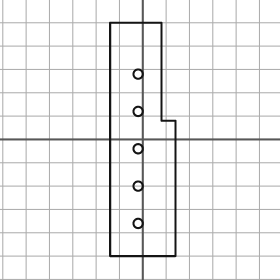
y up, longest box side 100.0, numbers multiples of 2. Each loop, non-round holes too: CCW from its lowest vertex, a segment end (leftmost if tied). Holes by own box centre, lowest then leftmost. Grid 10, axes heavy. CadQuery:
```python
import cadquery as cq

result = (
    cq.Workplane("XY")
    .moveTo(-14.0, -50.0)
    .lineTo(14.0, -50.0)
    .lineTo(14.0, 8.0)
    .lineTo(8.0, 8.0)
    .lineTo(8.0, 50.0)
    .lineTo(-14.0, 50.0)
    .close()
    .moveTo(-2.0, -36.0)
    .circle(2.0)
    .moveTo(-2.0, -20.0)
    .circle(2.0)
    .moveTo(-2.0, -4.0)
    .circle(2.0)
    .moveTo(-2.0, 12.0)
    .circle(2.0)
    .moveTo(-2.0, 28.0)
    .circle(2.0)
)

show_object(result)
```